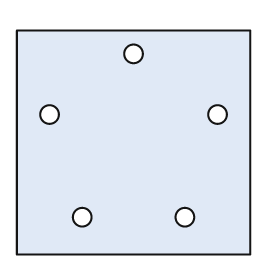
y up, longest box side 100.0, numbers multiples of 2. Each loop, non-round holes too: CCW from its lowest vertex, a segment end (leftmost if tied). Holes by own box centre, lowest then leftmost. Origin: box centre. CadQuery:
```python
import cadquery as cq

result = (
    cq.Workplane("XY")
    .moveTo(-50.0, -48.0)
    .lineTo(50.0, -48.0)
    .lineTo(50.0, 48.0)
    .lineTo(-50.0, 48.0)
    .close()
    .moveTo(-22.0, -32.0)
    .circle(4.0)
    .moveTo(22.0, -32.0)
    .circle(4.0)
    .moveTo(-36.0, 12.0)
    .circle(4.0)
    .moveTo(36.0, 12.0)
    .circle(4.0)
    .moveTo(0.0, 38.0)
    .circle(4.0)
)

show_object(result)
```